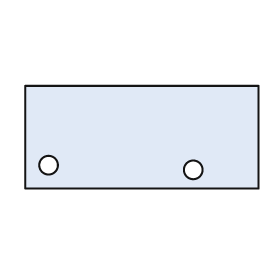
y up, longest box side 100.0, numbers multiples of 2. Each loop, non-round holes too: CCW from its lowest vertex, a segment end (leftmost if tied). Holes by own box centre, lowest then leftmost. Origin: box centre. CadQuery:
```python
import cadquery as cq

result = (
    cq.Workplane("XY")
    .moveTo(-50.0, -22.0)
    .lineTo(50.0, -22.0)
    .lineTo(50.0, 22.0)
    .lineTo(-50.0, 22.0)
    .close()
    .moveTo(22.0, -14.0)
    .circle(4.0)
    .moveTo(-40.0, -12.0)
    .circle(4.0)
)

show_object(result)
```